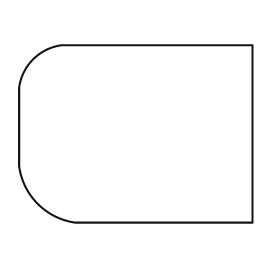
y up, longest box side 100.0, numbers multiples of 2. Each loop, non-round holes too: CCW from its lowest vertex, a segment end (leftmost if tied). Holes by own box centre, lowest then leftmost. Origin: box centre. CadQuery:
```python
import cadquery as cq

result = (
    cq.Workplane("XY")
    .moveTo(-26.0, -38.0)
    .lineTo(50.0, -38.0)
    .lineTo(50.0, 38.0)
    .lineTo(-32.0, 38.0)
    .threePointArc((-44.0, 32.0), (-50.0, 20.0))
    .lineTo(-50.0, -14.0)
    .threePointArc((-42.0, -30.0), (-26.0, -38.0))
    .close()
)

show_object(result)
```